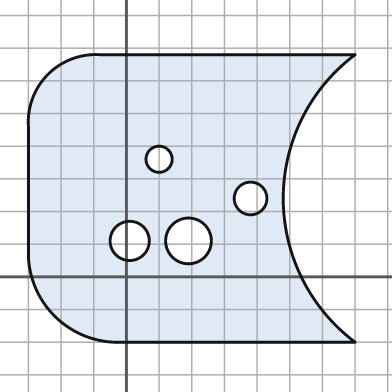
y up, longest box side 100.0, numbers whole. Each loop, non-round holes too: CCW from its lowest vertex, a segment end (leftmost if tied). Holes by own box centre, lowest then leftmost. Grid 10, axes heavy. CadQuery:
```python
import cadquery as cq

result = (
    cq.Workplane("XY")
    .moveTo(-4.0, -20.0)
    .lineTo(70.0, -20.0)
    .threePointArc((48.0, 24.0), (70.0, 68.0))
    .lineTo(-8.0, 68.0)
    .threePointArc((-24.0, 62.0), (-30.0, 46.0))
    .lineTo(-30.0, 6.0)
    .threePointArc((-22.0, -12.0), (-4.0, -20.0))
    .close()
    .moveTo(1.0, 11.0)
    .circle(6.0)
    .moveTo(19.0, 11.0)
    .circle(7.0)
    .moveTo(38.0, 24.0)
    .circle(5.0)
    .moveTo(10.0, 36.0)
    .circle(4.0)
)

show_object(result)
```